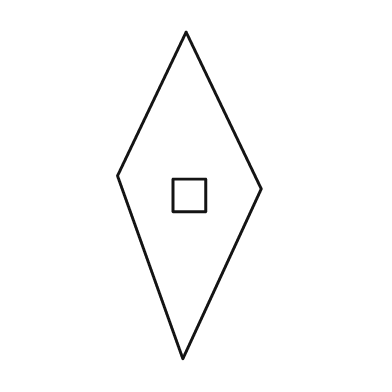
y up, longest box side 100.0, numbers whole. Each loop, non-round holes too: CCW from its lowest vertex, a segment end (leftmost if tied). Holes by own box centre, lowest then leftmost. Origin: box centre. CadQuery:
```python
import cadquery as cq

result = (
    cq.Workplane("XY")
    .moveTo(-2.0, -50.0)
    .lineTo(22.0, 2.0)
    .lineTo(-1.0, 50.0)
    .lineTo(-22.0, 6.0)
    .close()
    .moveTo(-5.0, -5.0)
    .lineTo(5.0, -5.0)
    .lineTo(5.0, 5.0)
    .lineTo(-5.0, 5.0)
    .close()
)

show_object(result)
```